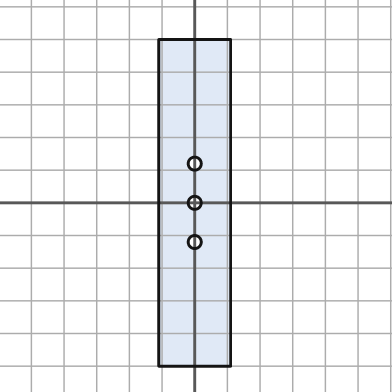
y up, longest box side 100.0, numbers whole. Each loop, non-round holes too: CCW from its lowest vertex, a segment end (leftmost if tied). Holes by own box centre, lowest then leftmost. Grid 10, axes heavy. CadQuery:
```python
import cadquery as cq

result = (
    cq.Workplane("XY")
    .moveTo(-11.0, -50.0)
    .lineTo(11.0, -50.0)
    .lineTo(11.0, 50.0)
    .lineTo(-11.0, 50.0)
    .close()
    .moveTo(0.0, -12.0)
    .circle(2.0)
    .moveTo(0.0, 0.0)
    .circle(2.0)
    .moveTo(0.0, 12.0)
    .circle(2.0)
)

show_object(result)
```